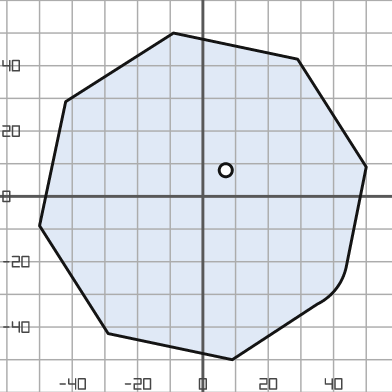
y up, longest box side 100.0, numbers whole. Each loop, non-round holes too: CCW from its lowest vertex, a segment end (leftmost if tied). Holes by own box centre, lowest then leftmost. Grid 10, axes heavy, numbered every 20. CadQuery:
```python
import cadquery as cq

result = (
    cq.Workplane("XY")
    .moveTo(9.0, -50.0)
    .lineTo(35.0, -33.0)
    .threePointArc((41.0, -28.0), (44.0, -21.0))
    .lineTo(50.0, 9.0)
    .lineTo(29.0, 42.0)
    .lineTo(-9.0, 50.0)
    .lineTo(-42.0, 29.0)
    .lineTo(-50.0, -9.0)
    .lineTo(-29.0, -42.0)
    .close()
    .moveTo(7.0, 8.0)
    .circle(2.0)
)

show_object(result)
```